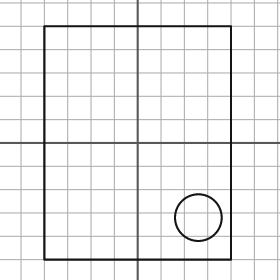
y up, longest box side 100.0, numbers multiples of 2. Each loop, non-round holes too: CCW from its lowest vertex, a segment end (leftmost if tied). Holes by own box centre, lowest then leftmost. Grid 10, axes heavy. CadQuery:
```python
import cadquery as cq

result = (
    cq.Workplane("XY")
    .moveTo(-40.0, -50.0)
    .lineTo(40.0, -50.0)
    .lineTo(40.0, 50.0)
    .lineTo(-40.0, 50.0)
    .close()
    .moveTo(26.0, -32.0)
    .circle(10.0)
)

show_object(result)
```